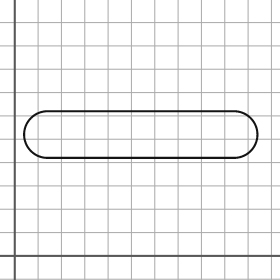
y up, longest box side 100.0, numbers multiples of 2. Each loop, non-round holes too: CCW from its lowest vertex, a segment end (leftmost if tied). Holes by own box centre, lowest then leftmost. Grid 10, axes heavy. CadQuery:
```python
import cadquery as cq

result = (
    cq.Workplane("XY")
    .moveTo(14.0, 42.0)
    .lineTo(94.0, 42.0)
    .threePointArc((104.0, 52.0), (94.0, 62.0))
    .lineTo(14.0, 62.0)
    .threePointArc((4.0, 52.0), (14.0, 42.0))
    .close()
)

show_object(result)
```